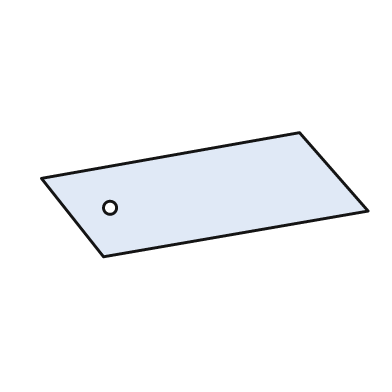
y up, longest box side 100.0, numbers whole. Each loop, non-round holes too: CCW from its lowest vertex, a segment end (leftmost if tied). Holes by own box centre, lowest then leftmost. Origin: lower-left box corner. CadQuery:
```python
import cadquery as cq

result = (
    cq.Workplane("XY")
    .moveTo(19.0, 0.0)
    .lineTo(100.0, 14.0)
    .lineTo(79.0, 38.0)
    .lineTo(0.0, 24.0)
    .close()
    .moveTo(21.0, 15.0)
    .circle(2.0)
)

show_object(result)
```